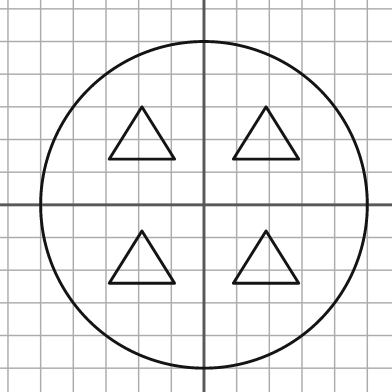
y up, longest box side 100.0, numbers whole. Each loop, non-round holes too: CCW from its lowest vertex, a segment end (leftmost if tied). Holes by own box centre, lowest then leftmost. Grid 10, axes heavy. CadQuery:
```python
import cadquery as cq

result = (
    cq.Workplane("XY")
    .moveTo(0.0, 0.0)
    .circle(50.0)
    .moveTo(-29.0, -24.0)
    .lineTo(-9.0, -24.0)
    .lineTo(-19.0, -8.0)
    .close()
    .moveTo(9.0, -24.0)
    .lineTo(29.0, -24.0)
    .lineTo(19.0, -8.0)
    .close()
    .moveTo(-29.0, 14.0)
    .lineTo(-9.0, 14.0)
    .lineTo(-19.0, 30.0)
    .close()
    .moveTo(9.0, 14.0)
    .lineTo(29.0, 14.0)
    .lineTo(19.0, 30.0)
    .close()
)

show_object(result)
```